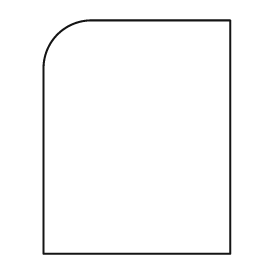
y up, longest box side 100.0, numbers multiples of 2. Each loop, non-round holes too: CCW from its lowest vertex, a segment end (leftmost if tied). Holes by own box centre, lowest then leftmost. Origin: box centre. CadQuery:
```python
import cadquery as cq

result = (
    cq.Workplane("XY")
    .moveTo(-40.0, -50.0)
    .lineTo(40.0, -50.0)
    .lineTo(40.0, 50.0)
    .lineTo(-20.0, 50.0)
    .threePointArc((-34.0, 44.0), (-40.0, 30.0))
    .close()
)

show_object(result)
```